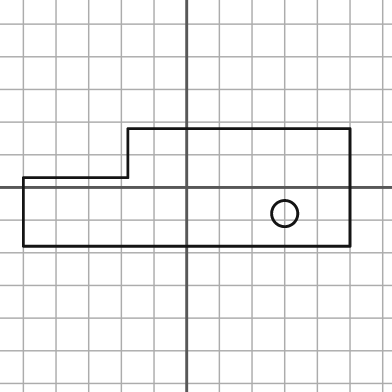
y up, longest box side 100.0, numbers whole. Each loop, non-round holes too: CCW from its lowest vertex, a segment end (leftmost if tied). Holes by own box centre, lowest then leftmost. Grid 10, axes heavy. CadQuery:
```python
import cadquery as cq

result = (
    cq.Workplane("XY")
    .moveTo(-50.0, -18.0)
    .lineTo(50.0, -18.0)
    .lineTo(50.0, 18.0)
    .lineTo(-18.0, 18.0)
    .lineTo(-18.0, 3.0)
    .lineTo(-50.0, 3.0)
    .close()
    .moveTo(30.0, -8.0)
    .circle(4.0)
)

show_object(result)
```